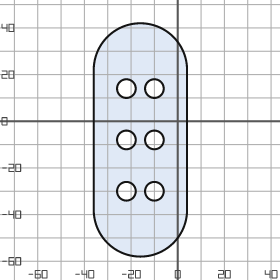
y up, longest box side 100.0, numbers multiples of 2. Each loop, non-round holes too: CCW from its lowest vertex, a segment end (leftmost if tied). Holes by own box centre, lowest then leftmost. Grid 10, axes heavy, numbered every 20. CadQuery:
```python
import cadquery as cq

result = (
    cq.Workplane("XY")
    .moveTo(-36.0, -38.0)
    .threePointArc((-16.0, -58.0), (4.0, -38.0))
    .lineTo(4.0, 22.0)
    .threePointArc((-16.0, 42.0), (-36.0, 22.0))
    .close()
    .moveTo(-22.0, -30.0)
    .circle(4.0)
    .moveTo(-10.0, -30.0)
    .circle(4.0)
    .moveTo(-22.0, -8.0)
    .circle(4.0)
    .moveTo(-10.0, -8.0)
    .circle(4.0)
    .moveTo(-22.0, 14.0)
    .circle(4.0)
    .moveTo(-10.0, 14.0)
    .circle(4.0)
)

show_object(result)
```